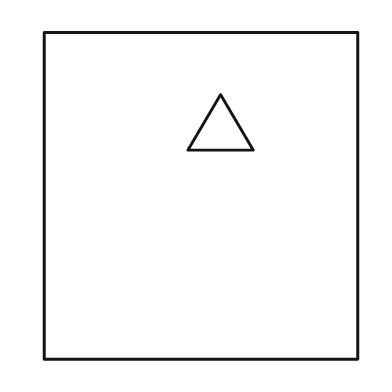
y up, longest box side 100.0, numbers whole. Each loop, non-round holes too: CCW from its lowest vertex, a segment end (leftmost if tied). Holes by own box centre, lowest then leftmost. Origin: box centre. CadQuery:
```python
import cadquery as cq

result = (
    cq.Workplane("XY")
    .moveTo(-48.0, -50.0)
    .lineTo(48.0, -50.0)
    .lineTo(48.0, 50.0)
    .lineTo(-48.0, 50.0)
    .close()
    .moveTo(-4.0, 14.0)
    .lineTo(16.0, 14.0)
    .lineTo(6.0, 31.0)
    .close()
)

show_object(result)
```